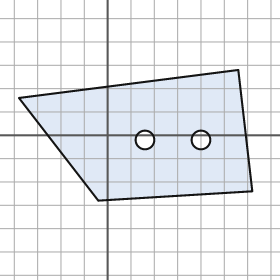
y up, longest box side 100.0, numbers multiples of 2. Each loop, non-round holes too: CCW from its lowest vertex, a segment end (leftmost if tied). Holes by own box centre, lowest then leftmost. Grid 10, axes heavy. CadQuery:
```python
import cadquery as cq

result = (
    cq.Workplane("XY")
    .moveTo(-4.0, -28.0)
    .lineTo(62.0, -24.0)
    .lineTo(56.0, 28.0)
    .lineTo(-38.0, 16.0)
    .close()
    .moveTo(16.0, -2.0)
    .circle(4.0)
    .moveTo(40.0, -2.0)
    .circle(4.0)
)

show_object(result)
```